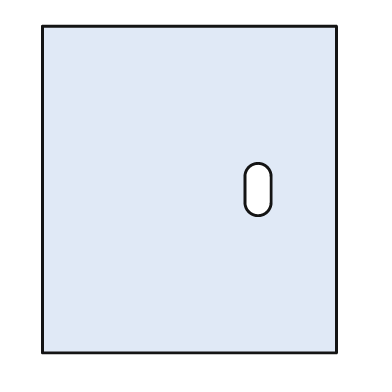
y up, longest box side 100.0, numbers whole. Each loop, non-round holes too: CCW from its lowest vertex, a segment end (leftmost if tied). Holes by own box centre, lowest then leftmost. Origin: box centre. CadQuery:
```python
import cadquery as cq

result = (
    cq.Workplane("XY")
    .moveTo(-45.0, -50.0)
    .lineTo(45.0, -50.0)
    .lineTo(45.0, 50.0)
    .lineTo(-45.0, 50.0)
    .close()
    .moveTo(17.0, -4.0)
    .threePointArc((21.0, -8.0), (25.0, -4.0))
    .lineTo(25.0, 4.0)
    .threePointArc((21.0, 8.0), (17.0, 4.0))
    .close()
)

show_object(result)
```